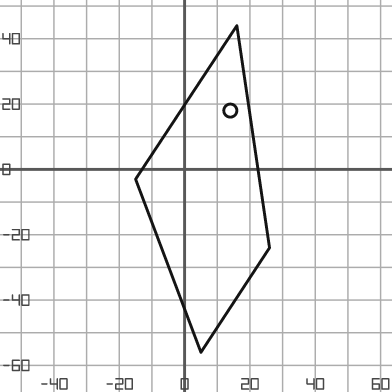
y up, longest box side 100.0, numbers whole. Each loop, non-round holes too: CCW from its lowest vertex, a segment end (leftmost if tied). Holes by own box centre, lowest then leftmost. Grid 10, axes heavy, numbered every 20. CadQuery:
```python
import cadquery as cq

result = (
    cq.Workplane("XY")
    .moveTo(5.0, -56.0)
    .lineTo(26.0, -24.0)
    .lineTo(16.0, 44.0)
    .lineTo(-15.0, -3.0)
    .close()
    .moveTo(14.0, 18.0)
    .circle(2.0)
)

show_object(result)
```